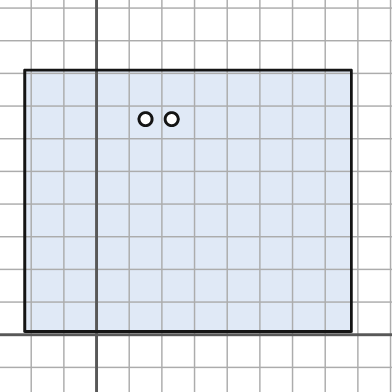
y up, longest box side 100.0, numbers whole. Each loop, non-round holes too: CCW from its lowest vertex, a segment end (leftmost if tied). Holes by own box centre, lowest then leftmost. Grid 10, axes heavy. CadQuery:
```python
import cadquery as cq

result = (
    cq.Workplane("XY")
    .moveTo(-22.0, 1.0)
    .lineTo(78.0, 1.0)
    .lineTo(78.0, 81.0)
    .lineTo(-22.0, 81.0)
    .close()
    .moveTo(15.0, 66.0)
    .circle(2.0)
    .moveTo(23.0, 66.0)
    .circle(2.0)
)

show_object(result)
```